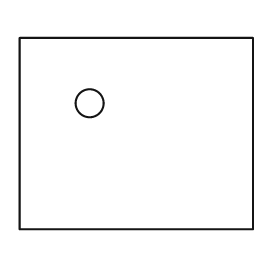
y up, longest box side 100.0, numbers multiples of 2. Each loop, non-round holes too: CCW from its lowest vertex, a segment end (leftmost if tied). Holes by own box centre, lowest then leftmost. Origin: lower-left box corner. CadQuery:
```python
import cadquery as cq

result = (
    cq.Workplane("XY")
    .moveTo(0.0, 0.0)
    .lineTo(100.0, 0.0)
    .lineTo(100.0, 82.0)
    .lineTo(0.0, 82.0)
    .close()
    .moveTo(30.0, 54.0)
    .circle(6.0)
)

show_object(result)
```